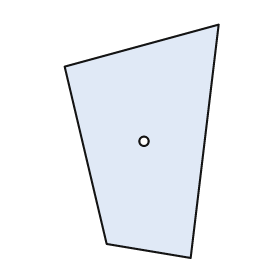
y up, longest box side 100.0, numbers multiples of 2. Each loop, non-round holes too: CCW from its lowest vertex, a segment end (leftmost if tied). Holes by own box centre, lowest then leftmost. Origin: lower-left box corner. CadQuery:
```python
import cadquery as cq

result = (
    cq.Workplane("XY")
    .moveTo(54.0, 0.0)
    .lineTo(66.0, 100.0)
    .lineTo(0.0, 82.0)
    .lineTo(18.0, 6.0)
    .close()
    .moveTo(34.0, 50.0)
    .circle(2.0)
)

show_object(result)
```